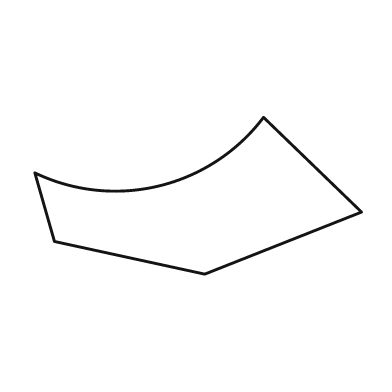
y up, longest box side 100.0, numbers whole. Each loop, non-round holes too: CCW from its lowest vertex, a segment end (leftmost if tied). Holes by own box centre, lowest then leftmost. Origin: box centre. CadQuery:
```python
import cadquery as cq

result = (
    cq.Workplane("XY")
    .moveTo(2.0, -24.0)
    .lineTo(50.0, -5.0)
    .lineTo(20.0, 24.0)
    .threePointArc((-12.0, 3.0), (-50.0, 7.0))
    .lineTo(-44.0, -14.0)
    .close()
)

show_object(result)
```